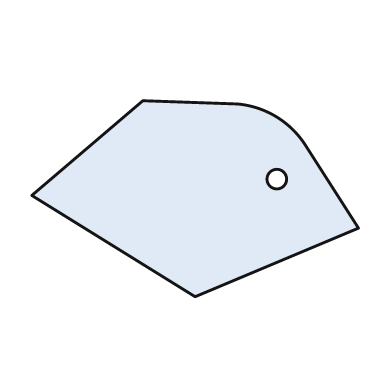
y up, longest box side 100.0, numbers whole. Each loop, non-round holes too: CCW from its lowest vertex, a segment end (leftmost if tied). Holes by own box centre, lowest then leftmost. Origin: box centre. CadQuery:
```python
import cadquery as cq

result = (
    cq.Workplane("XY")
    .moveTo(0.0, -30.0)
    .lineTo(50.0, -9.0)
    .lineTo(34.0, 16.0)
    .threePointArc((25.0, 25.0), (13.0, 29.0))
    .lineTo(-16.0, 30.0)
    .lineTo(-50.0, 1.0)
    .close()
    .moveTo(25.0, 6.0)
    .circle(3.0)
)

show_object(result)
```